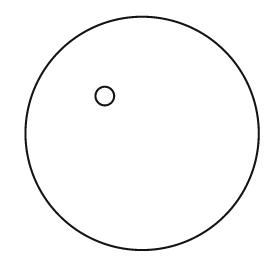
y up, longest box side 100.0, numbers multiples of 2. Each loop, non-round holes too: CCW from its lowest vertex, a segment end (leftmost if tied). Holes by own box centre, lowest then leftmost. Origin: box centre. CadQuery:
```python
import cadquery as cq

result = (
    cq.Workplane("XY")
    .moveTo(0.0, 0.0)
    .circle(50.0)
    .moveTo(-16.0, 16.0)
    .circle(4.0)
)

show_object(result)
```